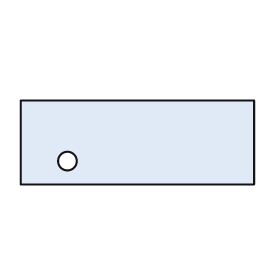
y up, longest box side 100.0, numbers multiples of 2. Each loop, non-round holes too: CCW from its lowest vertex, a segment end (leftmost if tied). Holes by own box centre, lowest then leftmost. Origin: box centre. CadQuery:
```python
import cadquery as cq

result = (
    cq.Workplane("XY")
    .moveTo(-50.0, -18.0)
    .lineTo(50.0, -18.0)
    .lineTo(50.0, 18.0)
    .lineTo(-50.0, 18.0)
    .close()
    .moveTo(-30.0, -8.0)
    .circle(4.0)
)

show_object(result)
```